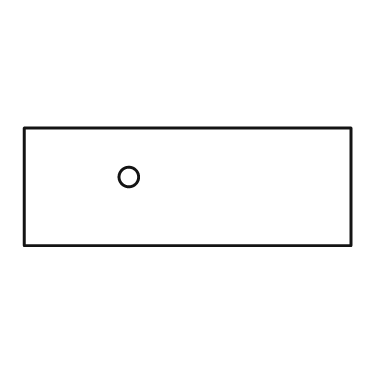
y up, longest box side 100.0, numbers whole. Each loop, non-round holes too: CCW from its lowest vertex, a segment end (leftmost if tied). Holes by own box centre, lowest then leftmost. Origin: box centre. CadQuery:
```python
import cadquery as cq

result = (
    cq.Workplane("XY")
    .moveTo(-50.0, -18.0)
    .lineTo(50.0, -18.0)
    .lineTo(50.0, 18.0)
    .lineTo(-50.0, 18.0)
    .close()
    .moveTo(-18.0, 3.0)
    .circle(3.0)
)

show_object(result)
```